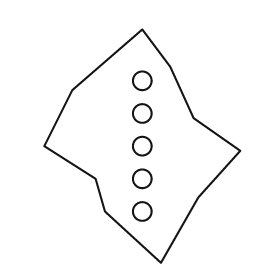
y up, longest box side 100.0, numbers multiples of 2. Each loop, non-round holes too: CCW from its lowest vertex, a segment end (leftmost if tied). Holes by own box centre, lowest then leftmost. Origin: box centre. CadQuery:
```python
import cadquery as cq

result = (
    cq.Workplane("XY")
    .moveTo(8.0, -50.0)
    .lineTo(24.0, -22.0)
    .lineTo(42.0, -2.0)
    .lineTo(22.0, 12.0)
    .lineTo(12.0, 34.0)
    .lineTo(0.0, 50.0)
    .lineTo(-30.0, 24.0)
    .lineTo(-42.0, 0.0)
    .lineTo(-20.0, -14.0)
    .lineTo(-16.0, -28.0)
    .close()
    .moveTo(0.0, -28.0)
    .circle(4.0)
    .moveTo(0.0, -14.0)
    .circle(4.0)
    .moveTo(0.0, 0.0)
    .circle(4.0)
    .moveTo(0.0, 14.0)
    .circle(4.0)
    .moveTo(0.0, 28.0)
    .circle(4.0)
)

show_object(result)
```